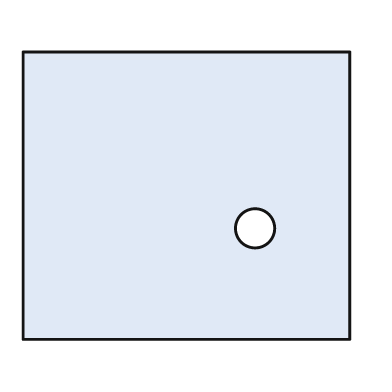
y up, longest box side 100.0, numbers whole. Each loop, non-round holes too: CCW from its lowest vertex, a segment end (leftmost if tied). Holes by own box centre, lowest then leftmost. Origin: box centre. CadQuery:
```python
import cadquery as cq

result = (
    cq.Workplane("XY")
    .moveTo(-50.0, -44.0)
    .lineTo(50.0, -44.0)
    .lineTo(50.0, 44.0)
    .lineTo(-50.0, 44.0)
    .close()
    .moveTo(21.0, -10.0)
    .circle(6.0)
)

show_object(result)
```